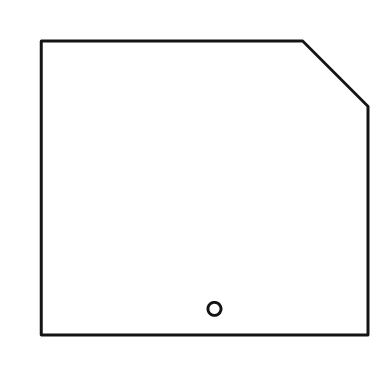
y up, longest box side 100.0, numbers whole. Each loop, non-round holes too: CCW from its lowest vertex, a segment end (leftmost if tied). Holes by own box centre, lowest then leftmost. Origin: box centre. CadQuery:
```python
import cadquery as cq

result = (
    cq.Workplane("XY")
    .moveTo(-50.0, -45.0)
    .lineTo(50.0, -45.0)
    .lineTo(50.0, 25.0)
    .lineTo(30.0, 45.0)
    .lineTo(-50.0, 45.0)
    .close()
    .moveTo(3.0, -37.0)
    .circle(2.0)
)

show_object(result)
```